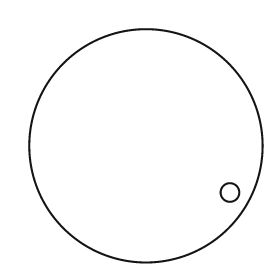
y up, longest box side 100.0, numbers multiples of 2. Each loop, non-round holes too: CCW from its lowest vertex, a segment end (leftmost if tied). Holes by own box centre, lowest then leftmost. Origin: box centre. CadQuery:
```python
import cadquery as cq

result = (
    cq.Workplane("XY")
    .moveTo(0.0, 0.0)
    .circle(50.0)
    .moveTo(36.0, -20.0)
    .circle(4.0)
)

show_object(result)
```